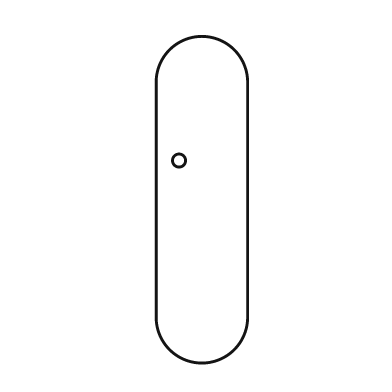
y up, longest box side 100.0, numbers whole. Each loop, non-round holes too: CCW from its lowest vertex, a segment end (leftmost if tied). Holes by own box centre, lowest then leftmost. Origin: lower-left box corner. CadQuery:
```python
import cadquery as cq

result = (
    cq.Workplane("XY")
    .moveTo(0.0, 14.0)
    .threePointArc((14.0, 0.0), (28.0, 14.0))
    .lineTo(28.0, 86.0)
    .threePointArc((14.0, 100.0), (0.0, 86.0))
    .close()
    .moveTo(7.0, 62.0)
    .circle(2.0)
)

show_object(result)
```